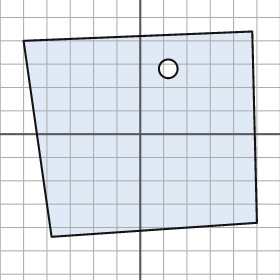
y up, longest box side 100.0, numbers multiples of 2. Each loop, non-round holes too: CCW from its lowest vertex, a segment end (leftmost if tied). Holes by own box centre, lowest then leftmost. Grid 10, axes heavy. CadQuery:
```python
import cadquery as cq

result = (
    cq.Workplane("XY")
    .moveTo(-38.0, -44.0)
    .lineTo(50.0, -38.0)
    .lineTo(48.0, 44.0)
    .lineTo(-50.0, 40.0)
    .close()
    .moveTo(12.0, 28.0)
    .circle(4.0)
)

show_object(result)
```